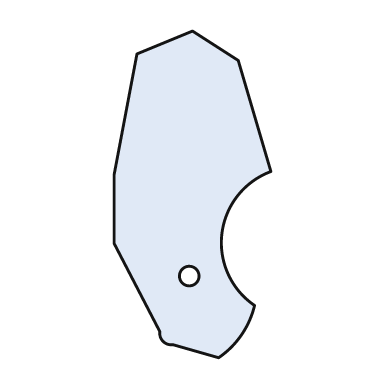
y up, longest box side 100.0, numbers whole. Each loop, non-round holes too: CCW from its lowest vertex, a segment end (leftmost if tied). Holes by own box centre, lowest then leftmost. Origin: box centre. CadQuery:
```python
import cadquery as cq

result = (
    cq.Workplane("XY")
    .moveTo(8.0, -50.0)
    .threePointArc((15.0, -43.0), (19.0, -34.0))
    .threePointArc((9.0, -12.0), (24.0, 7.0))
    .lineTo(14.0, 41.0)
    .lineTo(0.0, 50.0)
    .lineTo(-17.0, 43.0)
    .lineTo(-24.0, 6.0)
    .lineTo(-24.0, -15.0)
    .lineTo(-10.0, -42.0)
    .threePointArc((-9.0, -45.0), (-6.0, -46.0))
    .close()
    .moveTo(-1.0, -25.0)
    .circle(3.0)
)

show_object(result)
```